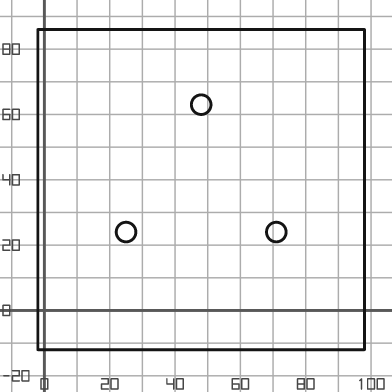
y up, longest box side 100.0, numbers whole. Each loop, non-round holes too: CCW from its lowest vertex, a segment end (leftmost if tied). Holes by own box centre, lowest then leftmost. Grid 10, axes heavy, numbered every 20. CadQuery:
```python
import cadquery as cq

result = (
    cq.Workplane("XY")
    .moveTo(-2.0, -12.0)
    .lineTo(98.0, -12.0)
    .lineTo(98.0, 86.0)
    .lineTo(-2.0, 86.0)
    .close()
    .moveTo(25.0, 24.0)
    .circle(3.0)
    .moveTo(71.0, 24.0)
    .circle(3.0)
    .moveTo(48.0, 63.0)
    .circle(3.0)
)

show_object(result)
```